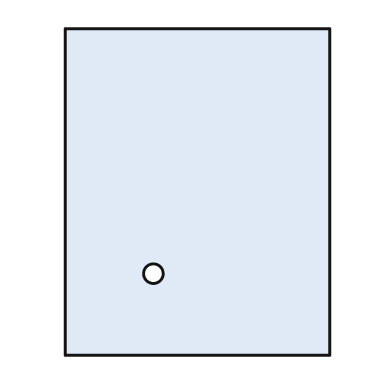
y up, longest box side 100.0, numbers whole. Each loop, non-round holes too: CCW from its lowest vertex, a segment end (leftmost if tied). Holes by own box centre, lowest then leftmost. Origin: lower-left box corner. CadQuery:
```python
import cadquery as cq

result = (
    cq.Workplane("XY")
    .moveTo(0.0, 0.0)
    .lineTo(81.0, 0.0)
    .lineTo(81.0, 100.0)
    .lineTo(0.0, 100.0)
    .close()
    .moveTo(27.0, 25.0)
    .circle(3.0)
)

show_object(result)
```